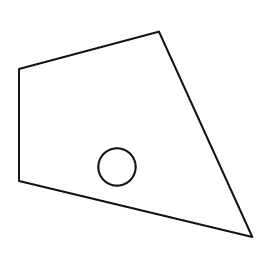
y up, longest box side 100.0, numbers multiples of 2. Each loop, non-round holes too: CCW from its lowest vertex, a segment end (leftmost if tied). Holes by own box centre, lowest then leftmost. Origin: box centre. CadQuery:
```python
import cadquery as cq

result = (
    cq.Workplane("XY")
    .moveTo(50.0, -44.0)
    .lineTo(10.0, 44.0)
    .lineTo(-50.0, 28.0)
    .lineTo(-50.0, -20.0)
    .close()
    .moveTo(-8.0, -14.0)
    .circle(8.0)
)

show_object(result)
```